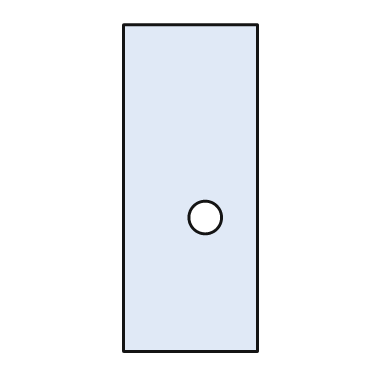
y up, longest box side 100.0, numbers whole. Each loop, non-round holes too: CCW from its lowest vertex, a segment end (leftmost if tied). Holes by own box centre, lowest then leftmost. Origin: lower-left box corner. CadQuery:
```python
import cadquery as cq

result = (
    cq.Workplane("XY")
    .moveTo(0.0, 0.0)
    .lineTo(41.0, 0.0)
    .lineTo(41.0, 100.0)
    .lineTo(0.0, 100.0)
    .close()
    .moveTo(25.0, 41.0)
    .circle(5.0)
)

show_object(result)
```